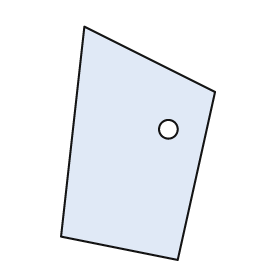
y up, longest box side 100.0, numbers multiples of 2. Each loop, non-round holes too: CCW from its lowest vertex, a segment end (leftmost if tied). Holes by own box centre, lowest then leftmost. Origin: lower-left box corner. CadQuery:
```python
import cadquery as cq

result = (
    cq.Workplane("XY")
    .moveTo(50.0, 0.0)
    .lineTo(66.0, 72.0)
    .lineTo(10.0, 100.0)
    .lineTo(0.0, 10.0)
    .close()
    .moveTo(46.0, 56.0)
    .circle(4.0)
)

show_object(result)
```